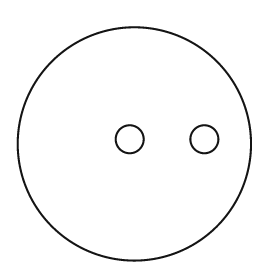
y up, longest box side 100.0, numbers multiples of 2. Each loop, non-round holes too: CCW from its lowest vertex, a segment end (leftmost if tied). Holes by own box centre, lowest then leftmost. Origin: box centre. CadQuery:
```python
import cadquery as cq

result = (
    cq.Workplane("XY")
    .moveTo(0.0, 0.0)
    .circle(50.0)
    .moveTo(-2.0, 2.0)
    .circle(6.0)
    .moveTo(30.0, 2.0)
    .circle(6.0)
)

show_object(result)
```